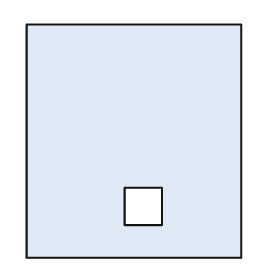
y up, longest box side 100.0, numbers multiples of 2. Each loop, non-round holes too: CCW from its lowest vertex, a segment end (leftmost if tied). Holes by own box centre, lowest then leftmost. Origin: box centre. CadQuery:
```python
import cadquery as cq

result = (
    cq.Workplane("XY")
    .moveTo(-46.0, -50.0)
    .lineTo(46.0, -50.0)
    .lineTo(46.0, 50.0)
    .lineTo(-46.0, 50.0)
    .close()
    .moveTo(-4.0, -36.0)
    .lineTo(12.0, -36.0)
    .lineTo(12.0, -20.0)
    .lineTo(-4.0, -20.0)
    .close()
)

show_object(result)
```